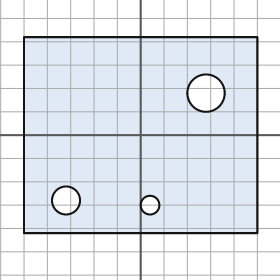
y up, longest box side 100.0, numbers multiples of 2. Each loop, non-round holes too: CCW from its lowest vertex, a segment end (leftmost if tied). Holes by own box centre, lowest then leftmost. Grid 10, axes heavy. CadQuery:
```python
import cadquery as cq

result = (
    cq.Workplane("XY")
    .moveTo(-50.0, -42.0)
    .lineTo(50.0, -42.0)
    .lineTo(50.0, 42.0)
    .lineTo(-50.0, 42.0)
    .close()
    .moveTo(4.0, -30.0)
    .circle(4.0)
    .moveTo(-32.0, -28.0)
    .circle(6.0)
    .moveTo(28.0, 18.0)
    .circle(8.0)
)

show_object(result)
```